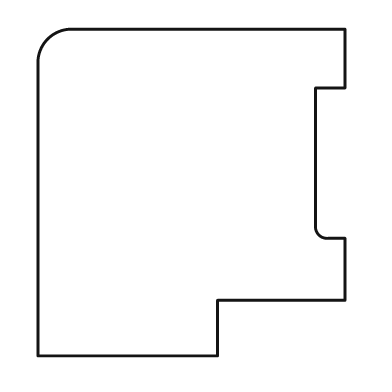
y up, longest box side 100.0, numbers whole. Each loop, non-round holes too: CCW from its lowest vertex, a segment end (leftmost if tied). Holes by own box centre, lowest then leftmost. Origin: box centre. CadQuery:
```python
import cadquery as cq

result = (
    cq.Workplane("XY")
    .moveTo(-47.0, -50.0)
    .lineTo(8.0, -50.0)
    .lineTo(8.0, -33.0)
    .lineTo(47.0, -33.0)
    .lineTo(47.0, -14.0)
    .lineTo(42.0, -14.0)
    .threePointArc((39.0, -13.0), (38.0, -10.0))
    .lineTo(38.0, 32.0)
    .lineTo(47.0, 32.0)
    .lineTo(47.0, 50.0)
    .lineTo(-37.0, 50.0)
    .threePointArc((-44.0, 47.0), (-47.0, 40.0))
    .close()
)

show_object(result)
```